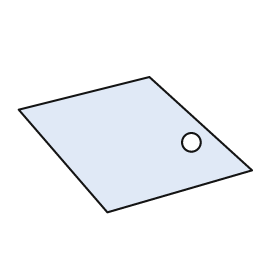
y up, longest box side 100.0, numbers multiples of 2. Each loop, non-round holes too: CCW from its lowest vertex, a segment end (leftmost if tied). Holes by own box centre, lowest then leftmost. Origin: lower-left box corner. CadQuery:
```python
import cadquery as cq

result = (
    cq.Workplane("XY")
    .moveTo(38.0, 0.0)
    .lineTo(100.0, 18.0)
    .lineTo(56.0, 58.0)
    .lineTo(0.0, 44.0)
    .close()
    .moveTo(74.0, 30.0)
    .circle(4.0)
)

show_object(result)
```